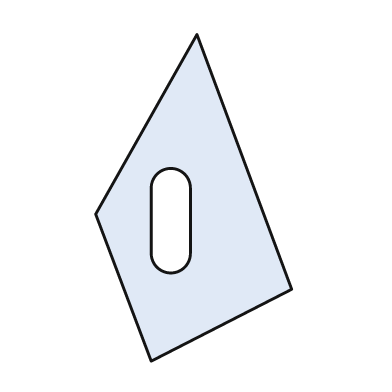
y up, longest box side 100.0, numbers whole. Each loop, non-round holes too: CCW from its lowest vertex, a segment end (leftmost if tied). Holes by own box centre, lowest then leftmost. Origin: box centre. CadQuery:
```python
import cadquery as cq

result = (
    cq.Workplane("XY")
    .moveTo(-13.0, -50.0)
    .lineTo(30.0, -28.0)
    .lineTo(1.0, 50.0)
    .lineTo(-30.0, -5.0)
    .close()
    .moveTo(-13.0, -17.0)
    .threePointArc((-7.0, -23.0), (-1.0, -17.0))
    .lineTo(-1.0, 3.0)
    .threePointArc((-7.0, 9.0), (-13.0, 3.0))
    .close()
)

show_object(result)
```